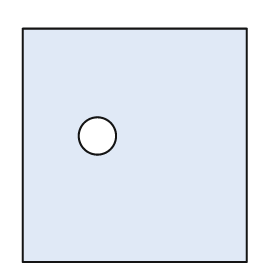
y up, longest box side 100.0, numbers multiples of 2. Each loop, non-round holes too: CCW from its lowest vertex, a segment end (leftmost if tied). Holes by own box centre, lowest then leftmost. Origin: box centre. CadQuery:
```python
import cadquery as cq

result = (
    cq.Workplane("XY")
    .moveTo(-48.0, -50.0)
    .lineTo(48.0, -50.0)
    .lineTo(48.0, 50.0)
    .lineTo(-48.0, 50.0)
    .close()
    .moveTo(-16.0, 4.0)
    .circle(8.0)
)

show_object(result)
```